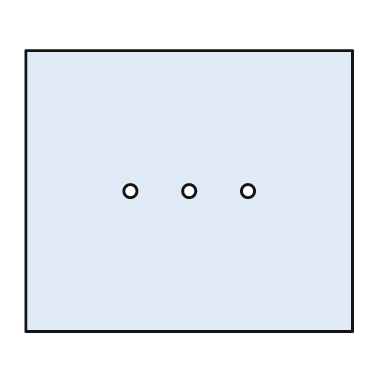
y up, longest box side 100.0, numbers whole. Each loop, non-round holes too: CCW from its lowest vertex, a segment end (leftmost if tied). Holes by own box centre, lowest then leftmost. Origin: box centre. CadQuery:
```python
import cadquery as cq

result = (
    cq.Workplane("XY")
    .moveTo(-50.0, -43.0)
    .lineTo(50.0, -43.0)
    .lineTo(50.0, 43.0)
    .lineTo(-50.0, 43.0)
    .close()
    .moveTo(-18.0, 0.0)
    .circle(2.0)
    .moveTo(0.0, 0.0)
    .circle(2.0)
    .moveTo(18.0, 0.0)
    .circle(2.0)
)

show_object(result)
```